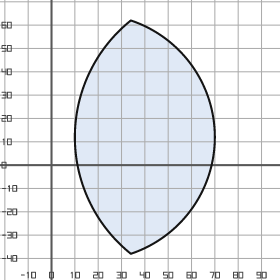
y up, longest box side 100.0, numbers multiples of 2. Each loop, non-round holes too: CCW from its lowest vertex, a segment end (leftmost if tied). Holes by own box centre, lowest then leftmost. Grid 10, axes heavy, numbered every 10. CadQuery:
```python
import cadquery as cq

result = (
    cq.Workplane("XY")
    .moveTo(34.0, -38.0)
    .threePointArc((70.0, 12.0), (34.0, 62.0))
    .threePointArc((10.0, 12.0), (34.0, -38.0))
    .close()
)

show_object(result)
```